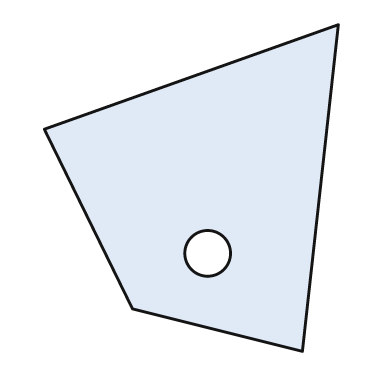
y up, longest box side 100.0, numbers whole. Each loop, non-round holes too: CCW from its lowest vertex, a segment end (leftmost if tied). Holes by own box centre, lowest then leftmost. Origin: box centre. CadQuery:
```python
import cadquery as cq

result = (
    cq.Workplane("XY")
    .moveTo(34.0, -50.0)
    .lineTo(45.0, 50.0)
    .lineTo(-45.0, 18.0)
    .lineTo(-18.0, -37.0)
    .close()
    .moveTo(5.0, -20.0)
    .circle(7.0)
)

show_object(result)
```